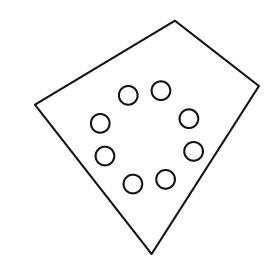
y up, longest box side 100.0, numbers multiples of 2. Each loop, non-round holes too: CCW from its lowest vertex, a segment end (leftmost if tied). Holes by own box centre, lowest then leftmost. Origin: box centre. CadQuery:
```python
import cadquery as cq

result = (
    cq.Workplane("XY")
    .moveTo(2.0, -50.0)
    .lineTo(48.0, 22.0)
    .lineTo(12.0, 50.0)
    .lineTo(-48.0, 14.0)
    .close()
    .moveTo(-6.0, -20.0)
    .circle(4.0)
    .moveTo(8.0, -18.0)
    .circle(4.0)
    .moveTo(-18.0, -8.0)
    .circle(4.0)
    .moveTo(20.0, -6.0)
    .circle(4.0)
    .moveTo(-20.0, 6.0)
    .circle(4.0)
    .moveTo(18.0, 8.0)
    .circle(4.0)
    .moveTo(-8.0, 18.0)
    .circle(4.0)
    .moveTo(6.0, 20.0)
    .circle(4.0)
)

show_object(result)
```